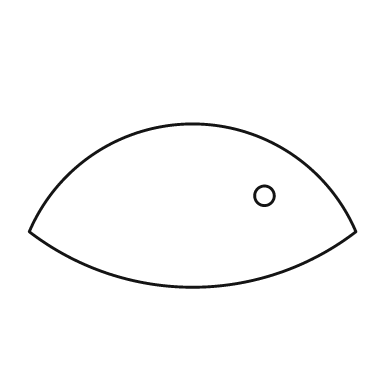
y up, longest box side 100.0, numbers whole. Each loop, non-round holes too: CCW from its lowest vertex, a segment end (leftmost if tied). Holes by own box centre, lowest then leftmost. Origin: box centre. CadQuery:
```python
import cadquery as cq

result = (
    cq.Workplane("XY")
    .moveTo(-50.0, -8.0)
    .threePointArc((0.0, -25.0), (50.0, -8.0))
    .threePointArc((0.0, 25.0), (-50.0, -8.0))
    .close()
    .moveTo(22.0, 3.0)
    .circle(3.0)
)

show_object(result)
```